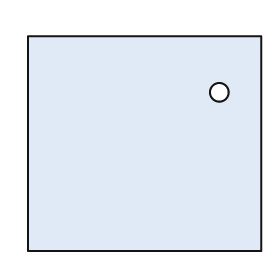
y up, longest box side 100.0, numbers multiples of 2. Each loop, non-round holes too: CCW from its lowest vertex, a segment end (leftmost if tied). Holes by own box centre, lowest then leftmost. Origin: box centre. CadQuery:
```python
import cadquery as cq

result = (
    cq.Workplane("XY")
    .moveTo(-50.0, -46.0)
    .lineTo(50.0, -46.0)
    .lineTo(50.0, 46.0)
    .lineTo(-50.0, 46.0)
    .close()
    .moveTo(32.0, 22.0)
    .circle(4.0)
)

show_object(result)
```